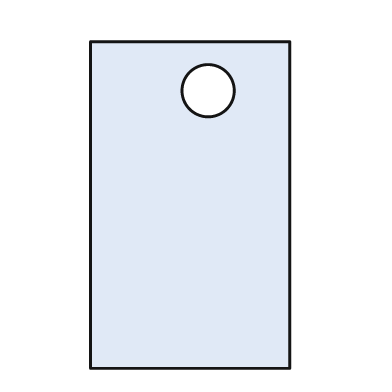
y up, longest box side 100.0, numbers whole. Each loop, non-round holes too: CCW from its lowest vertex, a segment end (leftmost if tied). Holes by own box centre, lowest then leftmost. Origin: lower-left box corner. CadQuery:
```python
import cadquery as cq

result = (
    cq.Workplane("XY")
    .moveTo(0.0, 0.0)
    .lineTo(61.0, 0.0)
    .lineTo(61.0, 100.0)
    .lineTo(0.0, 100.0)
    .close()
    .moveTo(36.0, 85.0)
    .circle(8.0)
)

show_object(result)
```